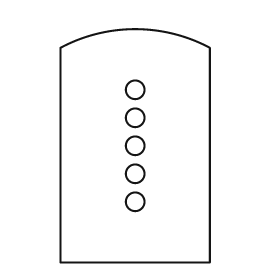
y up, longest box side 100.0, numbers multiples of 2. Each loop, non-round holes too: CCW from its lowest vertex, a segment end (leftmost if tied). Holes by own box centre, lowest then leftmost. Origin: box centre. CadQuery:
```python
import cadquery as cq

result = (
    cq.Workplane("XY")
    .moveTo(-32.0, -50.0)
    .lineTo(32.0, -50.0)
    .lineTo(32.0, 42.0)
    .threePointArc((0.0, 50.0), (-32.0, 42.0))
    .close()
    .moveTo(0.0, -24.0)
    .circle(4.0)
    .moveTo(0.0, -12.0)
    .circle(4.0)
    .moveTo(0.0, 0.0)
    .circle(4.0)
    .moveTo(0.0, 12.0)
    .circle(4.0)
    .moveTo(0.0, 24.0)
    .circle(4.0)
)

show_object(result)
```